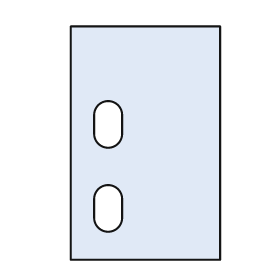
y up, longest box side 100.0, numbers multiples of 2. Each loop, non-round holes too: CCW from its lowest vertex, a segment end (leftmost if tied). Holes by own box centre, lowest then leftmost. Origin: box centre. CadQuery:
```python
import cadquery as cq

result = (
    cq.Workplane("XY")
    .moveTo(-32.0, -50.0)
    .lineTo(32.0, -50.0)
    .lineTo(32.0, 50.0)
    .lineTo(-32.0, 50.0)
    .close()
    .moveTo(-22.0, -32.0)
    .threePointArc((-16.0, -38.0), (-10.0, -32.0))
    .lineTo(-10.0, -24.0)
    .threePointArc((-16.0, -18.0), (-22.0, -24.0))
    .close()
    .moveTo(-22.0, 4.0)
    .threePointArc((-16.0, -2.0), (-10.0, 4.0))
    .lineTo(-10.0, 12.0)
    .threePointArc((-16.0, 18.0), (-22.0, 12.0))
    .close()
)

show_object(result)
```